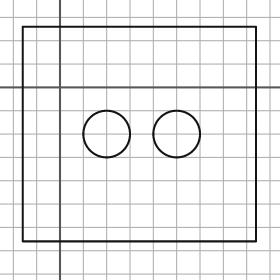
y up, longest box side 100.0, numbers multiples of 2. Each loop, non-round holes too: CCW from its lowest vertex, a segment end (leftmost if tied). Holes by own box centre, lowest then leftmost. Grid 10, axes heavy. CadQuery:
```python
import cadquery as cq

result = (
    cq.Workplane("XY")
    .moveTo(-16.0, -66.0)
    .lineTo(84.0, -66.0)
    .lineTo(84.0, 26.0)
    .lineTo(-16.0, 26.0)
    .close()
    .moveTo(20.0, -20.0)
    .circle(10.0)
    .moveTo(50.0, -20.0)
    .circle(10.0)
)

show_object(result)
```